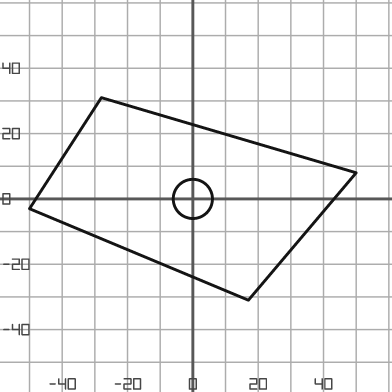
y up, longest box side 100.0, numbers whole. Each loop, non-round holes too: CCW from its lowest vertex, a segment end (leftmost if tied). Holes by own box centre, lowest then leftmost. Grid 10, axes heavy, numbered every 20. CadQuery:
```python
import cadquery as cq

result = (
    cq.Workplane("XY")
    .moveTo(17.0, -31.0)
    .lineTo(50.0, 8.0)
    .lineTo(-28.0, 31.0)
    .lineTo(-50.0, -3.0)
    .close()
    .moveTo(0.0, 0.0)
    .circle(6.0)
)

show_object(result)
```